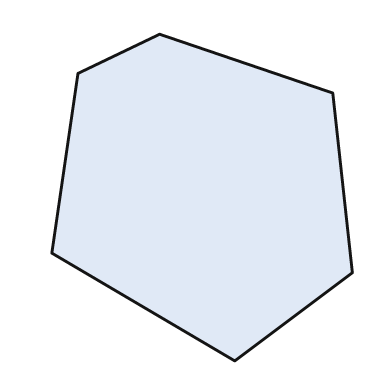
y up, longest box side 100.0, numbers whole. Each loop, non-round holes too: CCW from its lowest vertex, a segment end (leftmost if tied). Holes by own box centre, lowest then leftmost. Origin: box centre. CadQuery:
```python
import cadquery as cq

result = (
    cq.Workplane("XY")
    .moveTo(10.0, -50.0)
    .lineTo(46.0, -23.0)
    .lineTo(40.0, 32.0)
    .lineTo(-13.0, 50.0)
    .lineTo(-38.0, 38.0)
    .lineTo(-46.0, -17.0)
    .close()
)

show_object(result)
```